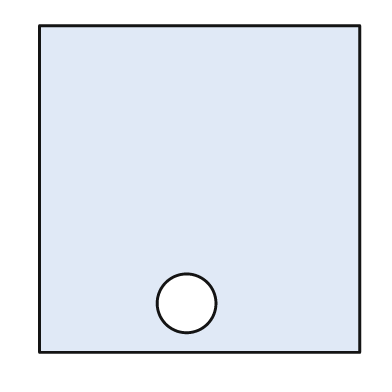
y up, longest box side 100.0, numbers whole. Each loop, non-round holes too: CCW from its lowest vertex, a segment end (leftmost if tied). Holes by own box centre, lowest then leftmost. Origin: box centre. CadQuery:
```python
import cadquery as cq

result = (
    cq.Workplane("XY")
    .moveTo(-49.0, -50.0)
    .lineTo(49.0, -50.0)
    .lineTo(49.0, 50.0)
    .lineTo(-49.0, 50.0)
    .close()
    .moveTo(-4.0, -35.0)
    .circle(9.0)
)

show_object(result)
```